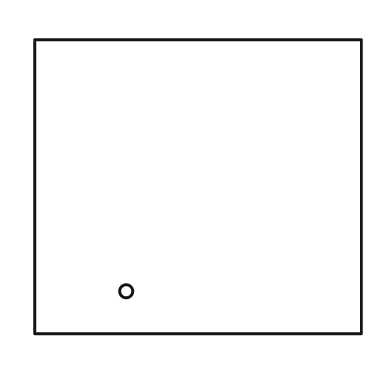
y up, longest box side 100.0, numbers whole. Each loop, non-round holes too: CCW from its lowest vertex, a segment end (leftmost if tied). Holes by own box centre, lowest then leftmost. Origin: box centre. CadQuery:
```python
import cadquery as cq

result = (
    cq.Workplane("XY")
    .moveTo(-50.0, -45.0)
    .lineTo(50.0, -45.0)
    .lineTo(50.0, 45.0)
    .lineTo(-50.0, 45.0)
    .close()
    .moveTo(-22.0, -32.0)
    .circle(2.0)
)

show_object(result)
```